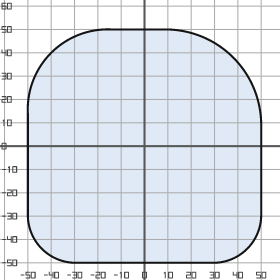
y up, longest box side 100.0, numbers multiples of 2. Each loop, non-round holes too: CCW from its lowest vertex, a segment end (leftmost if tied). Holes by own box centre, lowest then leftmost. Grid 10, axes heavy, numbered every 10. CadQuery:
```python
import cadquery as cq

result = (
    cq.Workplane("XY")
    .moveTo(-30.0, -50.0)
    .lineTo(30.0, -50.0)
    .threePointArc((44.0, -44.0), (50.0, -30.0))
    .lineTo(50.0, 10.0)
    .threePointArc((38.0, 38.0), (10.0, 50.0))
    .lineTo(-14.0, 50.0)
    .threePointArc((-40.0, 40.0), (-50.0, 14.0))
    .lineTo(-50.0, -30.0)
    .threePointArc((-44.0, -44.0), (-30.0, -50.0))
    .close()
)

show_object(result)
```